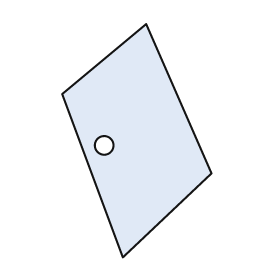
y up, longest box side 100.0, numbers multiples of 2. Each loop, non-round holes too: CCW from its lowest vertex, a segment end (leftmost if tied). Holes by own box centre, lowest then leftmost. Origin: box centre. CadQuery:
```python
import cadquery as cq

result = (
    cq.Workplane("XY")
    .moveTo(-6.0, -50.0)
    .lineTo(32.0, -14.0)
    .lineTo(4.0, 50.0)
    .lineTo(-32.0, 20.0)
    .close()
    .moveTo(-14.0, -2.0)
    .circle(4.0)
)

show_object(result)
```